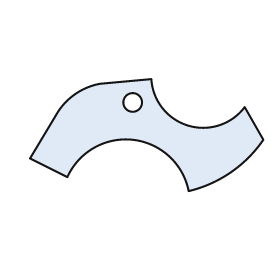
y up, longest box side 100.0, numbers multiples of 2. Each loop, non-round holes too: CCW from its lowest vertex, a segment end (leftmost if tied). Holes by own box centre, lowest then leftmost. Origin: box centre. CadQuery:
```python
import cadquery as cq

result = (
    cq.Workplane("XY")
    .moveTo(18.0, -24.0)
    .threePointArc((36.0, -16.0), (50.0, -2.0))
    .lineTo(42.0, 12.0)
    .threePointArc((18.0, 4.0), (2.0, 24.0))
    .lineTo(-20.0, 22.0)
    .threePointArc((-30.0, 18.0), (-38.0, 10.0))
    .lineTo(-50.0, -10.0)
    .lineTo(-34.0, -18.0)
    .threePointArc((-6.0, -2.0), (18.0, -24.0))
    .close()
    .moveTo(-6.0, 14.0)
    .circle(4.0)
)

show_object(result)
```